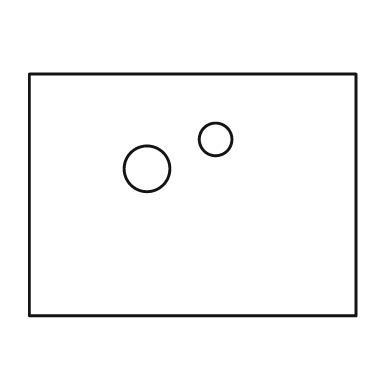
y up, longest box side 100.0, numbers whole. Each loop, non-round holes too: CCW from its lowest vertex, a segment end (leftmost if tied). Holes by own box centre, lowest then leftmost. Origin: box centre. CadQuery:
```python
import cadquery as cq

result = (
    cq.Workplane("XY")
    .moveTo(-50.0, -37.0)
    .lineTo(50.0, -37.0)
    .lineTo(50.0, 37.0)
    .lineTo(-50.0, 37.0)
    .close()
    .moveTo(-14.0, 8.0)
    .circle(7.0)
    .moveTo(7.0, 17.0)
    .circle(5.0)
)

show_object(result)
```